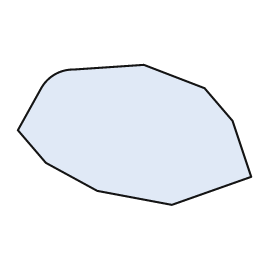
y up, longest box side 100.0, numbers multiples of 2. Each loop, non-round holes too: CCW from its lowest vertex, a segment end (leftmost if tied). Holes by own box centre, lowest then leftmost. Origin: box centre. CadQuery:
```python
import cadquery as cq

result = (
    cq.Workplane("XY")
    .moveTo(16.0, -30.0)
    .lineTo(50.0, -18.0)
    .lineTo(42.0, 6.0)
    .lineTo(30.0, 20.0)
    .lineTo(4.0, 30.0)
    .lineTo(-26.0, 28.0)
    .threePointArc((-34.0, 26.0), (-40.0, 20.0))
    .lineTo(-50.0, 2.0)
    .lineTo(-38.0, -12.0)
    .lineTo(-16.0, -24.0)
    .close()
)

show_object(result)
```